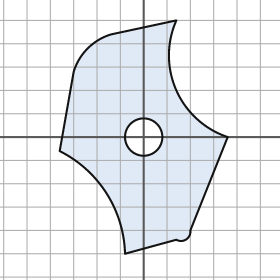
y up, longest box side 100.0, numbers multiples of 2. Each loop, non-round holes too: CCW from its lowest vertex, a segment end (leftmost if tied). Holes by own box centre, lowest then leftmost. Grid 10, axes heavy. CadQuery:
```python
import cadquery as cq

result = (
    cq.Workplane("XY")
    .moveTo(-8.0, -50.0)
    .lineTo(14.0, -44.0)
    .threePointArc((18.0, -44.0), (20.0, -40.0))
    .lineTo(36.0, 0.0)
    .threePointArc((14.0, 20.0), (14.0, 50.0))
    .lineTo(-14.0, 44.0)
    .threePointArc((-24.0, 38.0), (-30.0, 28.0))
    .lineTo(-36.0, -6.0)
    .threePointArc((-16.0, -24.0), (-8.0, -50.0))
    .close()
    .moveTo(0.0, 0.0)
    .circle(8.0)
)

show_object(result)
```